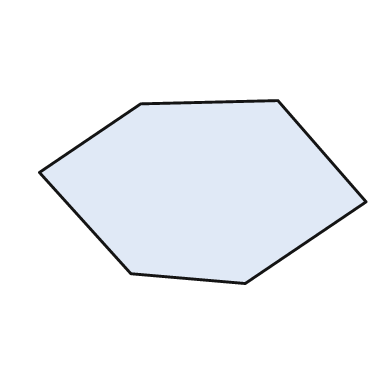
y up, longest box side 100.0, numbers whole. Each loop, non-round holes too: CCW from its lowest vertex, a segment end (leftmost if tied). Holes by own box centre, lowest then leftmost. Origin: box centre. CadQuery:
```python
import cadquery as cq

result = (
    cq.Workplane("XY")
    .moveTo(13.0, -28.0)
    .lineTo(50.0, -3.0)
    .lineTo(23.0, 28.0)
    .lineTo(-19.0, 27.0)
    .lineTo(-50.0, 6.0)
    .lineTo(-22.0, -25.0)
    .close()
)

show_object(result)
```